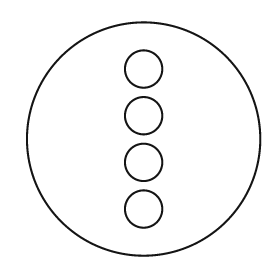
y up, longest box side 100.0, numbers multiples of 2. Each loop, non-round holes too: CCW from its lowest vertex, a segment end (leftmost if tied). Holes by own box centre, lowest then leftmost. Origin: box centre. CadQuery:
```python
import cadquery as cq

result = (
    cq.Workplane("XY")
    .moveTo(0.0, 0.0)
    .circle(50.0)
    .moveTo(0.0, -30.0)
    .circle(8.0)
    .moveTo(0.0, -10.0)
    .circle(8.0)
    .moveTo(0.0, 10.0)
    .circle(8.0)
    .moveTo(0.0, 30.0)
    .circle(8.0)
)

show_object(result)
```